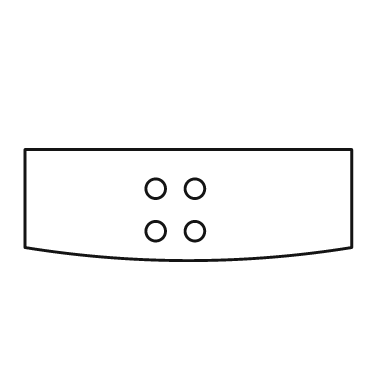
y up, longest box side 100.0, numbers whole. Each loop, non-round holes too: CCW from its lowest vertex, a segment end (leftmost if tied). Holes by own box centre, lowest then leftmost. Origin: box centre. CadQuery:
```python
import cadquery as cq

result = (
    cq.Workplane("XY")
    .moveTo(-50.0, -13.0)
    .threePointArc((0.0, -17.0), (50.0, -13.0))
    .lineTo(50.0, 17.0)
    .lineTo(-50.0, 17.0)
    .close()
    .moveTo(-10.0, -8.0)
    .circle(3.0)
    .moveTo(2.0, -8.0)
    .circle(3.0)
    .moveTo(-10.0, 5.0)
    .circle(3.0)
    .moveTo(2.0, 5.0)
    .circle(3.0)
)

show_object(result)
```